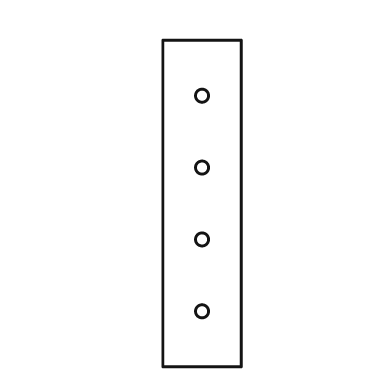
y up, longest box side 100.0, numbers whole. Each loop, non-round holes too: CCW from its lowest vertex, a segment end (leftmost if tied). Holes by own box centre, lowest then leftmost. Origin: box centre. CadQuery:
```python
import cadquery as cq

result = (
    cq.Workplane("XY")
    .moveTo(-12.0, -50.0)
    .lineTo(12.0, -50.0)
    .lineTo(12.0, 50.0)
    .lineTo(-12.0, 50.0)
    .close()
    .moveTo(0.0, -33.0)
    .circle(2.0)
    .moveTo(0.0, -11.0)
    .circle(2.0)
    .moveTo(0.0, 11.0)
    .circle(2.0)
    .moveTo(0.0, 33.0)
    .circle(2.0)
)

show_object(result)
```